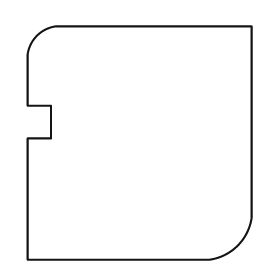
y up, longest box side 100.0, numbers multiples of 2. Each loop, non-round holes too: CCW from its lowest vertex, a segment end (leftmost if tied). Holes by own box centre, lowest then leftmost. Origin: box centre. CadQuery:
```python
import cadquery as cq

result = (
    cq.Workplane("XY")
    .moveTo(-48.0, -50.0)
    .lineTo(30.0, -50.0)
    .threePointArc((42.0, -44.0), (48.0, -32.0))
    .lineTo(48.0, 50.0)
    .lineTo(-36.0, 50.0)
    .threePointArc((-44.0, 46.0), (-48.0, 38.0))
    .lineTo(-48.0, 16.0)
    .lineTo(-38.0, 16.0)
    .lineTo(-38.0, 2.0)
    .lineTo(-48.0, 2.0)
    .close()
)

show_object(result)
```